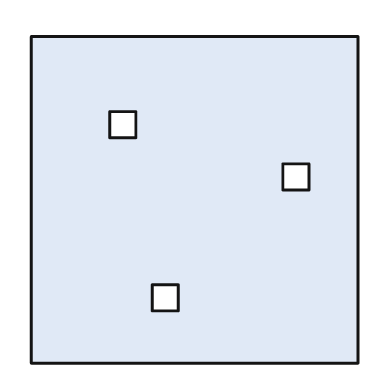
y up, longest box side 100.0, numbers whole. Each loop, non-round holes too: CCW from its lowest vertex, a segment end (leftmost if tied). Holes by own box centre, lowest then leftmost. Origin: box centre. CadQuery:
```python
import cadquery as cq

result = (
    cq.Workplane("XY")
    .moveTo(-50.0, -50.0)
    .lineTo(50.0, -50.0)
    .lineTo(50.0, 50.0)
    .lineTo(-50.0, 50.0)
    .close()
    .moveTo(-13.0, -34.0)
    .lineTo(-5.0, -34.0)
    .lineTo(-5.0, -26.0)
    .lineTo(-13.0, -26.0)
    .close()
    .moveTo(27.0, 3.0)
    .lineTo(35.0, 3.0)
    .lineTo(35.0, 11.0)
    .lineTo(27.0, 11.0)
    .close()
    .moveTo(-26.0, 19.0)
    .lineTo(-18.0, 19.0)
    .lineTo(-18.0, 27.0)
    .lineTo(-26.0, 27.0)
    .close()
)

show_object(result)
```